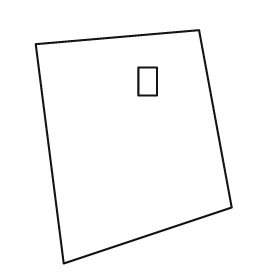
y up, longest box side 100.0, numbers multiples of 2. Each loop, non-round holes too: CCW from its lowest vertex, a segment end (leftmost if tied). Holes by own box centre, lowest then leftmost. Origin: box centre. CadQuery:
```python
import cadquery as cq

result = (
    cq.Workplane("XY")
    .moveTo(-30.0, -50.0)
    .lineTo(42.0, -26.0)
    .lineTo(28.0, 50.0)
    .lineTo(-42.0, 44.0)
    .close()
    .moveTo(2.0, 22.0)
    .lineTo(10.0, 22.0)
    .lineTo(10.0, 34.0)
    .lineTo(2.0, 34.0)
    .close()
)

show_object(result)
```